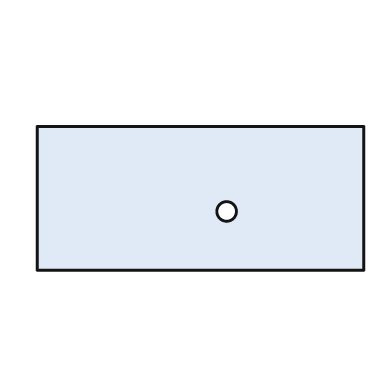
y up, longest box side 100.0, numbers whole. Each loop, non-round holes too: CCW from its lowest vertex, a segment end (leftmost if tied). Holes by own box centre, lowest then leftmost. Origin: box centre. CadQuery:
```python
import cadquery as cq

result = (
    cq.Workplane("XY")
    .moveTo(-50.0, -22.0)
    .lineTo(50.0, -22.0)
    .lineTo(50.0, 22.0)
    .lineTo(-50.0, 22.0)
    .close()
    .moveTo(8.0, -4.0)
    .circle(3.0)
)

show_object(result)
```